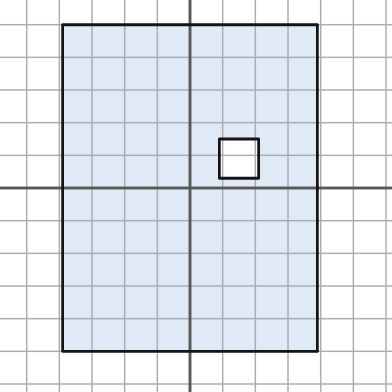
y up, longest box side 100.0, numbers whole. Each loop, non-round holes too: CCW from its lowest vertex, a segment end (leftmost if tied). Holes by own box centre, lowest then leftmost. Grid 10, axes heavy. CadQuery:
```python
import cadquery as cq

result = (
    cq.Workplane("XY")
    .moveTo(-39.0, -50.0)
    .lineTo(39.0, -50.0)
    .lineTo(39.0, 50.0)
    .lineTo(-39.0, 50.0)
    .close()
    .moveTo(9.0, 3.0)
    .lineTo(21.0, 3.0)
    .lineTo(21.0, 15.0)
    .lineTo(9.0, 15.0)
    .close()
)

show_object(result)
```